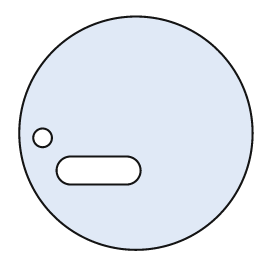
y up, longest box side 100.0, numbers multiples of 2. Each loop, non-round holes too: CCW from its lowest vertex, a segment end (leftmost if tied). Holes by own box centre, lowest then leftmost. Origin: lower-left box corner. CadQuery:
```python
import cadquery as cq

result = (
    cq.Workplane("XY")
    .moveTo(50.0, 50.0)
    .circle(50.0)
    .moveTo(22.0, 28.0)
    .lineTo(46.0, 28.0)
    .threePointArc((52.0, 34.0), (46.0, 40.0))
    .lineTo(22.0, 40.0)
    .threePointArc((16.0, 34.0), (22.0, 28.0))
    .close()
    .moveTo(10.0, 48.0)
    .circle(4.0)
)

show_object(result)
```